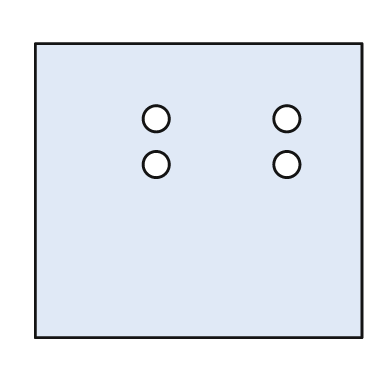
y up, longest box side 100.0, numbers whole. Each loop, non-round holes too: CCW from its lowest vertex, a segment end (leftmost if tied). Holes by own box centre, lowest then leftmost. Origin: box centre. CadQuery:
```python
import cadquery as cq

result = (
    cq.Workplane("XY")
    .moveTo(-50.0, -45.0)
    .lineTo(50.0, -45.0)
    .lineTo(50.0, 45.0)
    .lineTo(-50.0, 45.0)
    .close()
    .moveTo(-13.0, 8.0)
    .circle(4.0)
    .moveTo(27.0, 8.0)
    .circle(4.0)
    .moveTo(-13.0, 22.0)
    .circle(4.0)
    .moveTo(27.0, 22.0)
    .circle(4.0)
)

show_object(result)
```